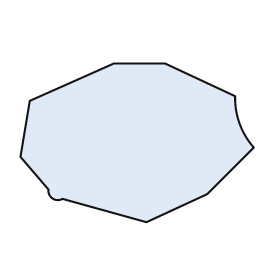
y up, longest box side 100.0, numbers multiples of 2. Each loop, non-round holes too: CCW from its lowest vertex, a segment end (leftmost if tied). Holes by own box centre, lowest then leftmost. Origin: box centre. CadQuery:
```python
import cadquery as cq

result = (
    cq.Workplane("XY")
    .moveTo(4.0, -34.0)
    .lineTo(30.0, -22.0)
    .lineTo(50.0, -2.0)
    .threePointArc((44.0, 8.0), (42.0, 20.0))
    .lineTo(12.0, 34.0)
    .lineTo(-10.0, 34.0)
    .lineTo(-46.0, 18.0)
    .lineTo(-50.0, -6.0)
    .lineTo(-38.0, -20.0)
    .threePointArc((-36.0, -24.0), (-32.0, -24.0))
    .close()
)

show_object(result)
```